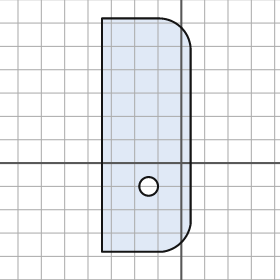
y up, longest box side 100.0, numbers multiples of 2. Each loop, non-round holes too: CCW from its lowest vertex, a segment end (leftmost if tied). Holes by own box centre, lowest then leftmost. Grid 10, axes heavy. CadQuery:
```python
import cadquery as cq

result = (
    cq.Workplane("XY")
    .moveTo(-34.0, -38.0)
    .lineTo(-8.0, -38.0)
    .threePointArc((0.0, -34.0), (4.0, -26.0))
    .lineTo(4.0, 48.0)
    .threePointArc((0.0, 58.0), (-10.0, 62.0))
    .lineTo(-34.0, 62.0)
    .close()
    .moveTo(-14.0, -10.0)
    .circle(4.0)
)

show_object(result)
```